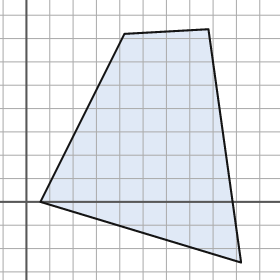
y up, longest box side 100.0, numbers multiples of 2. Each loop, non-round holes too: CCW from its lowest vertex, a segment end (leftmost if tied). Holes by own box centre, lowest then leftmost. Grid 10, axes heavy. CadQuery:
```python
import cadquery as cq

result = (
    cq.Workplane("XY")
    .moveTo(92.0, -26.0)
    .lineTo(78.0, 74.0)
    .lineTo(42.0, 72.0)
    .lineTo(6.0, 0.0)
    .close()
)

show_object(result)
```